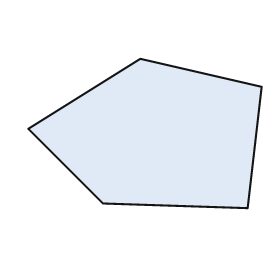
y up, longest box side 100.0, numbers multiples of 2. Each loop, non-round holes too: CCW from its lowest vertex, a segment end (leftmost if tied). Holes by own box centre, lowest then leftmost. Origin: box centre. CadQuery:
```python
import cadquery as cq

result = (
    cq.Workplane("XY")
    .moveTo(44.0, -32.0)
    .lineTo(50.0, 20.0)
    .lineTo(-2.0, 32.0)
    .lineTo(-50.0, 2.0)
    .lineTo(-18.0, -30.0)
    .close()
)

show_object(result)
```